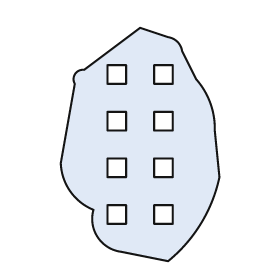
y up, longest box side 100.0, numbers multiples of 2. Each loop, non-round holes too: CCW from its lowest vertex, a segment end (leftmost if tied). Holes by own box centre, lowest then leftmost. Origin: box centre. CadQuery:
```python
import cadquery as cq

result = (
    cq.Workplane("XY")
    .moveTo(12.0, -50.0)
    .threePointArc((26.0, -34.0), (34.0, -14.0))
    .lineTo(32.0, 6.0)
    .threePointArc((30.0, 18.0), (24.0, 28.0))
    .lineTo(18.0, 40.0)
    .threePointArc((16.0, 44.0), (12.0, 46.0))
    .lineTo(0.0, 50.0)
    .lineTo(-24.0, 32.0)
    .threePointArc((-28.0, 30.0), (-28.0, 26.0))
    .lineTo(-34.0, -8.0)
    .threePointArc((-30.0, -20.0), (-20.0, -28.0))
    .threePointArc((-18.0, -40.0), (-8.0, -46.0))
    .close()
    .moveTo(-14.0, -34.0)
    .lineTo(-6.0, -34.0)
    .lineTo(-6.0, -26.0)
    .lineTo(-14.0, -26.0)
    .close()
    .moveTo(6.0, -34.0)
    .lineTo(14.0, -34.0)
    .lineTo(14.0, -26.0)
    .lineTo(6.0, -26.0)
    .close()
    .moveTo(-14.0, -14.0)
    .lineTo(-6.0, -14.0)
    .lineTo(-6.0, -6.0)
    .lineTo(-14.0, -6.0)
    .close()
    .moveTo(6.0, -14.0)
    .lineTo(14.0, -14.0)
    .lineTo(14.0, -6.0)
    .lineTo(6.0, -6.0)
    .close()
    .moveTo(-14.0, 6.0)
    .lineTo(-6.0, 6.0)
    .lineTo(-6.0, 14.0)
    .lineTo(-14.0, 14.0)
    .close()
    .moveTo(6.0, 6.0)
    .lineTo(14.0, 6.0)
    .lineTo(14.0, 14.0)
    .lineTo(6.0, 14.0)
    .close()
    .moveTo(-14.0, 26.0)
    .lineTo(-6.0, 26.0)
    .lineTo(-6.0, 34.0)
    .lineTo(-14.0, 34.0)
    .close()
    .moveTo(6.0, 26.0)
    .lineTo(14.0, 26.0)
    .lineTo(14.0, 34.0)
    .lineTo(6.0, 34.0)
    .close()
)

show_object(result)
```